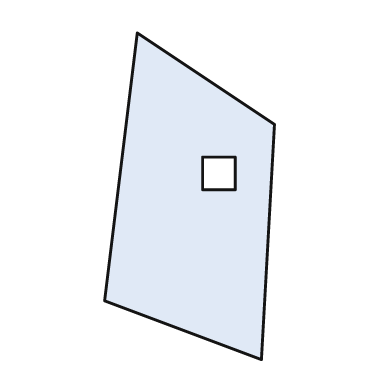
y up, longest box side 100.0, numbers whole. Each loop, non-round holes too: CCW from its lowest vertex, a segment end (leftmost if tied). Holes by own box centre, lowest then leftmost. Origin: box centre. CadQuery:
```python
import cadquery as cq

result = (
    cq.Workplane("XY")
    .moveTo(22.0, -50.0)
    .lineTo(26.0, 22.0)
    .lineTo(-16.0, 50.0)
    .lineTo(-26.0, -32.0)
    .close()
    .moveTo(4.0, 2.0)
    .lineTo(14.0, 2.0)
    .lineTo(14.0, 12.0)
    .lineTo(4.0, 12.0)
    .close()
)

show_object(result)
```